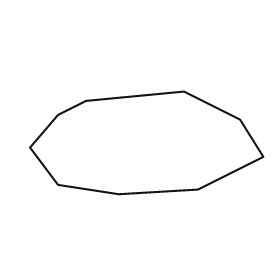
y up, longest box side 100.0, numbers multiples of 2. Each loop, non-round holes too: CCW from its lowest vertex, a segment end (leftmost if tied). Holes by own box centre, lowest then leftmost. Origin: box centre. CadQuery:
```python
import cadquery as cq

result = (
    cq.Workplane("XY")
    .moveTo(-12.0, -22.0)
    .lineTo(22.0, -20.0)
    .lineTo(50.0, -6.0)
    .lineTo(40.0, 10.0)
    .lineTo(16.0, 22.0)
    .lineTo(-26.0, 18.0)
    .lineTo(-38.0, 12.0)
    .lineTo(-50.0, -2.0)
    .lineTo(-38.0, -18.0)
    .close()
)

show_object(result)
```